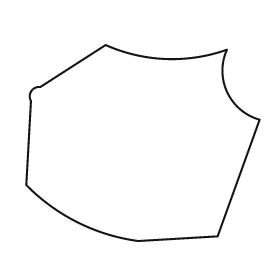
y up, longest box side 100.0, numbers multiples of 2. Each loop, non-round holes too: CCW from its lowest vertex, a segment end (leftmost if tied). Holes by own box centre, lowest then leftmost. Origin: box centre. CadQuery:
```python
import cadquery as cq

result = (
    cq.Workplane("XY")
    .moveTo(-2.0, -42.0)
    .lineTo(32.0, -40.0)
    .lineTo(50.0, 10.0)
    .threePointArc((36.0, 22.0), (36.0, 40.0))
    .threePointArc((10.0, 36.0), (-16.0, 42.0))
    .lineTo(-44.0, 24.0)
    .threePointArc((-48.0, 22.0), (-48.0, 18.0))
    .lineTo(-50.0, -18.0)
    .threePointArc((-28.0, -34.0), (-2.0, -42.0))
    .close()
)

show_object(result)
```